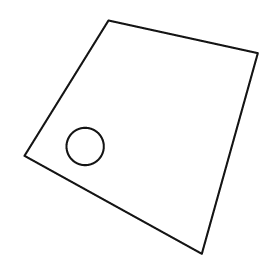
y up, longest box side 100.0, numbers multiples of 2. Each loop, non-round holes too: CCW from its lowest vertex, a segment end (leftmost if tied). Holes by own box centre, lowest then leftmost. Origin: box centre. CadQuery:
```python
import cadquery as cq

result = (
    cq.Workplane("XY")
    .moveTo(26.0, -50.0)
    .lineTo(50.0, 36.0)
    .lineTo(-14.0, 50.0)
    .lineTo(-50.0, -8.0)
    .close()
    .moveTo(-24.0, -4.0)
    .circle(8.0)
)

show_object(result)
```